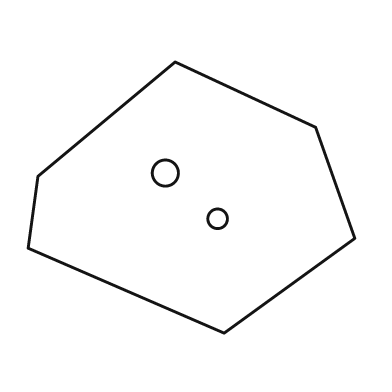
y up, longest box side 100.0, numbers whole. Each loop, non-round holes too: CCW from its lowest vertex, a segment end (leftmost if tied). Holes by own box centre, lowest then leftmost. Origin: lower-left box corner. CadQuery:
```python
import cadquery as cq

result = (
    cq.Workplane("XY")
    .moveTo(60.0, 0.0)
    .lineTo(100.0, 29.0)
    .lineTo(88.0, 63.0)
    .lineTo(45.0, 83.0)
    .lineTo(3.0, 48.0)
    .lineTo(0.0, 26.0)
    .close()
    .moveTo(58.0, 35.0)
    .circle(3.0)
    .moveTo(42.0, 49.0)
    .circle(4.0)
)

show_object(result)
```